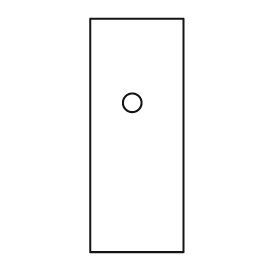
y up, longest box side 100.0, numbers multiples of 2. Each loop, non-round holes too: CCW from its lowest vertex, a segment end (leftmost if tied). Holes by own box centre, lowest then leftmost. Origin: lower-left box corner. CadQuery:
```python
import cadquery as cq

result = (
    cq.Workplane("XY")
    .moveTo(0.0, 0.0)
    .lineTo(40.0, 0.0)
    .lineTo(40.0, 100.0)
    .lineTo(0.0, 100.0)
    .close()
    .moveTo(18.0, 64.0)
    .circle(4.0)
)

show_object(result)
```